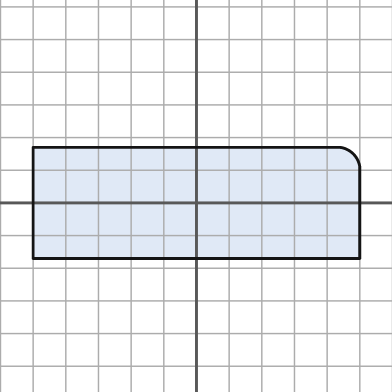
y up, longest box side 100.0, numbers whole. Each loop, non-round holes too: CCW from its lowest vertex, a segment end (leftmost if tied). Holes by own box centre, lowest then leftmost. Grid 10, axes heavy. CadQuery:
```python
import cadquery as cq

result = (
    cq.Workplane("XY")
    .moveTo(-50.0, -17.0)
    .lineTo(50.0, -17.0)
    .lineTo(50.0, 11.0)
    .threePointArc((48.0, 15.0), (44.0, 17.0))
    .lineTo(-50.0, 17.0)
    .close()
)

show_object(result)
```